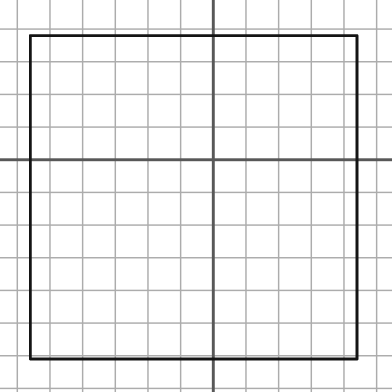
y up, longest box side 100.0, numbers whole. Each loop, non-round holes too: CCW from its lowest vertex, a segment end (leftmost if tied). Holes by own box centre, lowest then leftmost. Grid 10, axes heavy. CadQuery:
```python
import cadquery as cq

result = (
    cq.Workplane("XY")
    .moveTo(-56.0, -61.0)
    .lineTo(44.0, -61.0)
    .lineTo(44.0, 38.0)
    .lineTo(-56.0, 38.0)
    .close()
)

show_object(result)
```